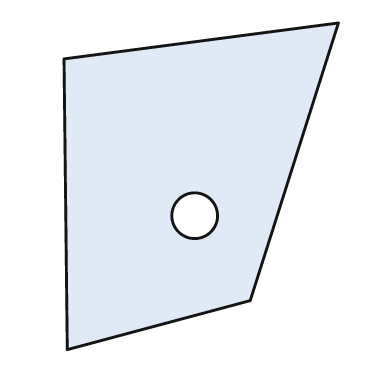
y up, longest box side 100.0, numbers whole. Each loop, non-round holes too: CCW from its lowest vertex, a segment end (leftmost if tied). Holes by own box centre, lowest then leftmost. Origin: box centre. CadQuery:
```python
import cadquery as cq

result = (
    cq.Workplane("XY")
    .moveTo(-41.0, -50.0)
    .lineTo(15.0, -35.0)
    .lineTo(42.0, 50.0)
    .lineTo(-42.0, 39.0)
    .close()
    .moveTo(-2.0, -9.0)
    .circle(7.0)
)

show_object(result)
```